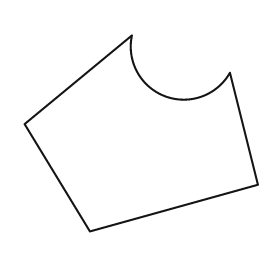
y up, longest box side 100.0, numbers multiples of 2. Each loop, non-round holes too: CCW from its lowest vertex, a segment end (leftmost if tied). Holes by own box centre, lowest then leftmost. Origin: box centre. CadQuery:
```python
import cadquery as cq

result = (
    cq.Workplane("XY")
    .moveTo(-22.0, -42.0)
    .lineTo(50.0, -22.0)
    .lineTo(38.0, 26.0)
    .threePointArc((10.0, 16.0), (-4.0, 42.0))
    .lineTo(-50.0, 4.0)
    .close()
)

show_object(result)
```